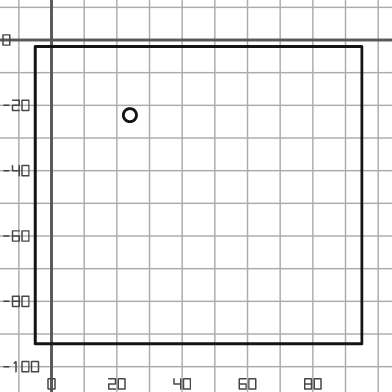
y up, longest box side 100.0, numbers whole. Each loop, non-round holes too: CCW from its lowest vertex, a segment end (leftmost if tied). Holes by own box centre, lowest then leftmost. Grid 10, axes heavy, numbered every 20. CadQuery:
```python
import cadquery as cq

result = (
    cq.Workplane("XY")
    .moveTo(-5.0, -93.0)
    .lineTo(95.0, -93.0)
    .lineTo(95.0, -2.0)
    .lineTo(-5.0, -2.0)
    .close()
    .moveTo(24.0, -23.0)
    .circle(2.0)
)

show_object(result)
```